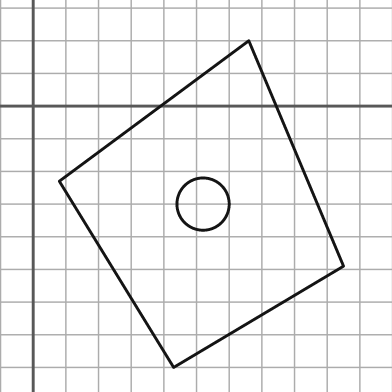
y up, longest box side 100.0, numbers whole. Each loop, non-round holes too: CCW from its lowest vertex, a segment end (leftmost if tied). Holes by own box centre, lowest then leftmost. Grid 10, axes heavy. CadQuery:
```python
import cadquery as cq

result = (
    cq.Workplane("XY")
    .moveTo(43.0, -80.0)
    .lineTo(95.0, -49.0)
    .lineTo(66.0, 20.0)
    .lineTo(8.0, -23.0)
    .close()
    .moveTo(52.0, -30.0)
    .circle(8.0)
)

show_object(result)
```